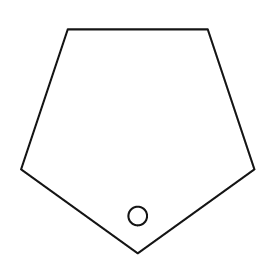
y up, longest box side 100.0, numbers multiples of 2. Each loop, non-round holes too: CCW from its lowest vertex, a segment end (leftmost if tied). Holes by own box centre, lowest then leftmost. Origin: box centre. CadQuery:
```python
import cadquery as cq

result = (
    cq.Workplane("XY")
    .moveTo(0.0, -48.0)
    .lineTo(50.0, -12.0)
    .lineTo(30.0, 48.0)
    .lineTo(-30.0, 48.0)
    .lineTo(-50.0, -12.0)
    .close()
    .moveTo(0.0, -32.0)
    .circle(4.0)
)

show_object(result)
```